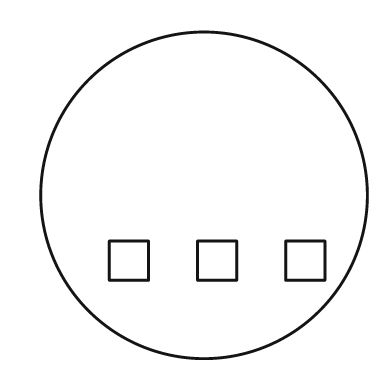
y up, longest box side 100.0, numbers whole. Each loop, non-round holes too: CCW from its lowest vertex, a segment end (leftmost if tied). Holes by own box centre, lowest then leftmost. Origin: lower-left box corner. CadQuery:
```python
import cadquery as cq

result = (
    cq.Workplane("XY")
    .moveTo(50.0, 50.0)
    .circle(50.0)
    .moveTo(21.0, 24.0)
    .lineTo(33.0, 24.0)
    .lineTo(33.0, 36.0)
    .lineTo(21.0, 36.0)
    .close()
    .moveTo(48.0, 24.0)
    .lineTo(60.0, 24.0)
    .lineTo(60.0, 36.0)
    .lineTo(48.0, 36.0)
    .close()
    .moveTo(75.0, 24.0)
    .lineTo(87.0, 24.0)
    .lineTo(87.0, 36.0)
    .lineTo(75.0, 36.0)
    .close()
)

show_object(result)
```